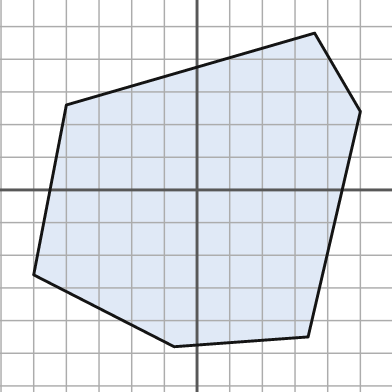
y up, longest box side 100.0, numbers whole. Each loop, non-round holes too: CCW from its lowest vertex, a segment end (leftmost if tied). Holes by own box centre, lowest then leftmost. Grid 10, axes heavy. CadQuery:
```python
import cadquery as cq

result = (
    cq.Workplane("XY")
    .moveTo(-7.0, -48.0)
    .lineTo(34.0, -45.0)
    .lineTo(50.0, 24.0)
    .lineTo(36.0, 48.0)
    .lineTo(-40.0, 26.0)
    .lineTo(-50.0, -26.0)
    .close()
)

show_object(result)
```